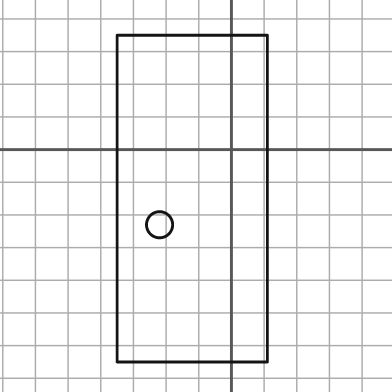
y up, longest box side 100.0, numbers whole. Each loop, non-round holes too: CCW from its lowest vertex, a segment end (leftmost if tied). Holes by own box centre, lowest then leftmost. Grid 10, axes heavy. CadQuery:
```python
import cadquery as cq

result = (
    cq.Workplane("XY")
    .moveTo(-35.0, -65.0)
    .lineTo(11.0, -65.0)
    .lineTo(11.0, 35.0)
    .lineTo(-35.0, 35.0)
    .close()
    .moveTo(-22.0, -23.0)
    .circle(4.0)
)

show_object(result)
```